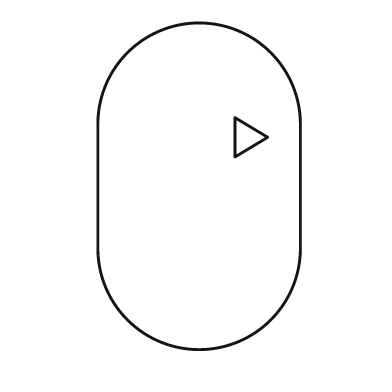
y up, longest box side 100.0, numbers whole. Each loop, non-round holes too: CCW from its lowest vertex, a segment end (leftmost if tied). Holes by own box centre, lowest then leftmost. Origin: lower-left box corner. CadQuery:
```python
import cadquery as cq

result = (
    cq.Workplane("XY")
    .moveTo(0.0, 31.0)
    .threePointArc((31.0, 0.0), (62.0, 31.0))
    .lineTo(62.0, 69.0)
    .threePointArc((31.0, 100.0), (0.0, 69.0))
    .close()
    .moveTo(42.0, 59.0)
    .lineTo(52.0, 65.0)
    .lineTo(42.0, 71.0)
    .close()
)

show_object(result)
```